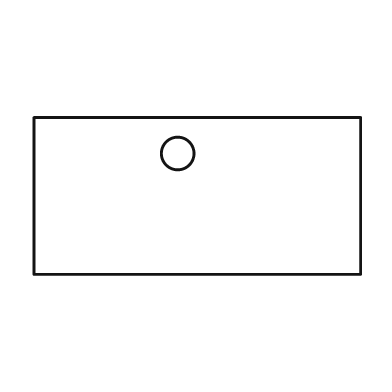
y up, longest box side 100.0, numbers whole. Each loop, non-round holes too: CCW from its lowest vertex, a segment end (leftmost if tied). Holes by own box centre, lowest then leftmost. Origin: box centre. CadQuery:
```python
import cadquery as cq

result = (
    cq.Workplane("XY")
    .moveTo(-50.0, -24.0)
    .lineTo(50.0, -24.0)
    .lineTo(50.0, 24.0)
    .lineTo(-50.0, 24.0)
    .close()
    .moveTo(-6.0, 13.0)
    .circle(5.0)
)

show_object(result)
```